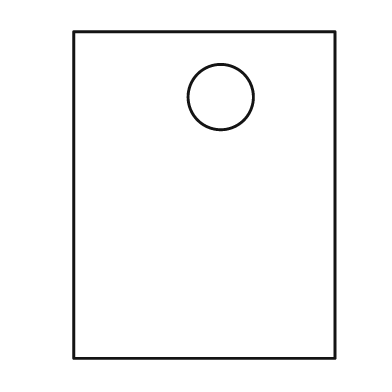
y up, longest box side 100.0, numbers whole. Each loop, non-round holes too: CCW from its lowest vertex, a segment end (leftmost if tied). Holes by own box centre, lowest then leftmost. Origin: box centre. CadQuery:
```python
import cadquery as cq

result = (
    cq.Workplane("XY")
    .moveTo(-40.0, -50.0)
    .lineTo(40.0, -50.0)
    .lineTo(40.0, 50.0)
    .lineTo(-40.0, 50.0)
    .close()
    .moveTo(5.0, 30.0)
    .circle(10.0)
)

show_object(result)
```